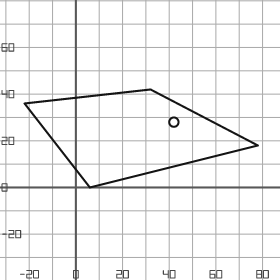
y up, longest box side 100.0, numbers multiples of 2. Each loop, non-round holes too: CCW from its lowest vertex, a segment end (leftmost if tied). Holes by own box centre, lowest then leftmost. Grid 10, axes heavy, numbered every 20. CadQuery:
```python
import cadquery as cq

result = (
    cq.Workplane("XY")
    .moveTo(6.0, 0.0)
    .lineTo(78.0, 18.0)
    .lineTo(32.0, 42.0)
    .lineTo(-22.0, 36.0)
    .close()
    .moveTo(42.0, 28.0)
    .circle(2.0)
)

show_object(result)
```